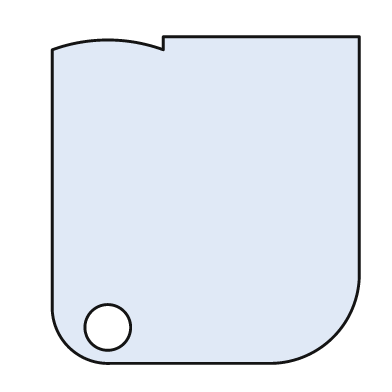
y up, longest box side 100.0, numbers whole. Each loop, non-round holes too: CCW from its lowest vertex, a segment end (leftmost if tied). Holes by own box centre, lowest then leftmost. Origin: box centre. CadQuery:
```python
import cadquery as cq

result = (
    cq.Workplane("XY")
    .moveTo(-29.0, -50.0)
    .lineTo(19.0, -50.0)
    .threePointArc((39.0, -42.0), (47.0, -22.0))
    .lineTo(47.0, 50.0)
    .lineTo(-13.0, 50.0)
    .lineTo(-13.0, 46.0)
    .threePointArc((-30.0, 49.0), (-47.0, 46.0))
    .lineTo(-47.0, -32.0)
    .threePointArc((-42.0, -45.0), (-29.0, -50.0))
    .close()
    .moveTo(-30.0, -39.0)
    .circle(7.0)
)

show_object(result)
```